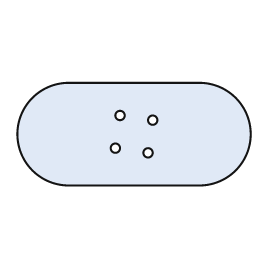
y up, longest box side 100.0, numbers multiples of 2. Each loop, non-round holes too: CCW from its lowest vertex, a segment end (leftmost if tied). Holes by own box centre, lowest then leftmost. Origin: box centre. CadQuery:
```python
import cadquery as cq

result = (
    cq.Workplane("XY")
    .moveTo(-28.0, -22.0)
    .lineTo(28.0, -22.0)
    .threePointArc((50.0, 0.0), (28.0, 22.0))
    .lineTo(-28.0, 22.0)
    .threePointArc((-50.0, 0.0), (-28.0, -22.0))
    .close()
    .moveTo(6.0, -8.0)
    .circle(2.0)
    .moveTo(-8.0, -6.0)
    .circle(2.0)
    .moveTo(8.0, 6.0)
    .circle(2.0)
    .moveTo(-6.0, 8.0)
    .circle(2.0)
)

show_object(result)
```